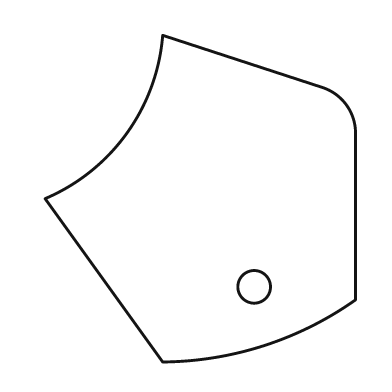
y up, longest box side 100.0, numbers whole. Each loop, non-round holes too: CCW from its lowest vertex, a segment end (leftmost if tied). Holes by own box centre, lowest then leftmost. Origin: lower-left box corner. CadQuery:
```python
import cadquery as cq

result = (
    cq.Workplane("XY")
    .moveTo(36.0, 0.0)
    .threePointArc((67.0, 5.0), (95.0, 19.0))
    .lineTo(95.0, 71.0)
    .threePointArc((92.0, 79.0), (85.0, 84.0))
    .lineTo(36.0, 100.0)
    .threePointArc((25.0, 70.0), (0.0, 50.0))
    .close()
    .moveTo(64.0, 23.0)
    .circle(5.0)
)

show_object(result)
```